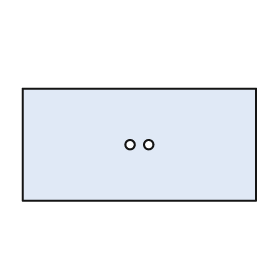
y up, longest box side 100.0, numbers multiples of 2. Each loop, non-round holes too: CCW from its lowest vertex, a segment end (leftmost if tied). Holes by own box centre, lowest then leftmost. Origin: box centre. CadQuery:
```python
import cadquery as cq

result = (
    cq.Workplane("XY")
    .moveTo(-50.0, -24.0)
    .lineTo(50.0, -24.0)
    .lineTo(50.0, 24.0)
    .lineTo(-50.0, 24.0)
    .close()
    .moveTo(-4.0, 0.0)
    .circle(2.0)
    .moveTo(4.0, 0.0)
    .circle(2.0)
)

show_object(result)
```